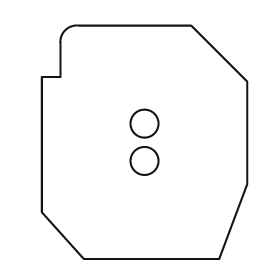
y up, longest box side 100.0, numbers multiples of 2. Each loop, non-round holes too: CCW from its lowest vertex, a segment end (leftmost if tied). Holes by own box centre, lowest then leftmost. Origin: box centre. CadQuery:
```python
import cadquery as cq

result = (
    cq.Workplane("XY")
    .moveTo(-26.0, -50.0)
    .lineTo(32.0, -50.0)
    .lineTo(44.0, -18.0)
    .lineTo(44.0, 26.0)
    .lineTo(20.0, 50.0)
    .lineTo(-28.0, 50.0)
    .threePointArc((-34.0, 48.0), (-36.0, 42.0))
    .lineTo(-36.0, 28.0)
    .lineTo(-44.0, 28.0)
    .lineTo(-44.0, -30.0)
    .close()
    .moveTo(0.0, -8.0)
    .circle(6.0)
    .moveTo(0.0, 8.0)
    .circle(6.0)
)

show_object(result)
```